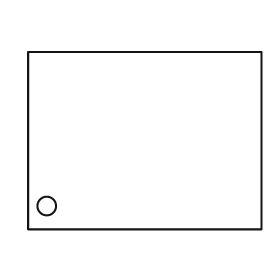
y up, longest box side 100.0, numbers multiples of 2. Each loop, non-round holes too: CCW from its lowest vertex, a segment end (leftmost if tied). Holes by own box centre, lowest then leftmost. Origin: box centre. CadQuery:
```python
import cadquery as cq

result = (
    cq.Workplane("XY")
    .moveTo(-50.0, -38.0)
    .lineTo(50.0, -38.0)
    .lineTo(50.0, 38.0)
    .lineTo(-50.0, 38.0)
    .close()
    .moveTo(-42.0, -28.0)
    .circle(4.0)
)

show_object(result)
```